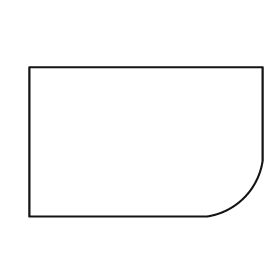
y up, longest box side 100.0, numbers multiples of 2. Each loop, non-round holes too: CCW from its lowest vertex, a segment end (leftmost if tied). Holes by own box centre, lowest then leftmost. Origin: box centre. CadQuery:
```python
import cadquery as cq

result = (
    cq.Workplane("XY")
    .moveTo(-50.0, -32.0)
    .lineTo(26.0, -32.0)
    .threePointArc((42.0, -24.0), (50.0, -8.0))
    .lineTo(50.0, 32.0)
    .lineTo(-50.0, 32.0)
    .close()
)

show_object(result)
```